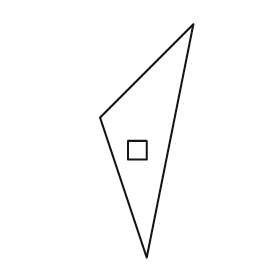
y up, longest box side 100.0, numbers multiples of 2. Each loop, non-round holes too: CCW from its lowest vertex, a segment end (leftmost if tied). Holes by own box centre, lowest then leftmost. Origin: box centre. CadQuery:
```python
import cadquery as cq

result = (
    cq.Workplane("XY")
    .moveTo(0.0, -50.0)
    .lineTo(20.0, 50.0)
    .lineTo(-20.0, 10.0)
    .close()
    .moveTo(-8.0, -8.0)
    .lineTo(0.0, -8.0)
    .lineTo(0.0, 0.0)
    .lineTo(-8.0, 0.0)
    .close()
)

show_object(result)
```